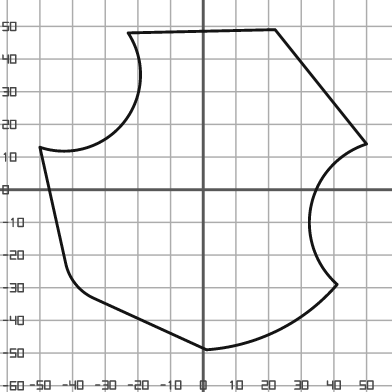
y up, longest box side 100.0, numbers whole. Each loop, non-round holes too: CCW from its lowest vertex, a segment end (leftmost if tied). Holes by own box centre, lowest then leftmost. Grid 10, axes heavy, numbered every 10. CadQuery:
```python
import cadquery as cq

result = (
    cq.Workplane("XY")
    .moveTo(1.0, -49.0)
    .threePointArc((23.0, -43.0), (41.0, -29.0))
    .threePointArc((33.0, -5.0), (50.0, 14.0))
    .lineTo(22.0, 49.0)
    .lineTo(-23.0, 48.0)
    .threePointArc((-24.0, 21.0), (-50.0, 13.0))
    .lineTo(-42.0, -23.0)
    .threePointArc((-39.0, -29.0), (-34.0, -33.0))
    .close()
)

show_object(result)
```